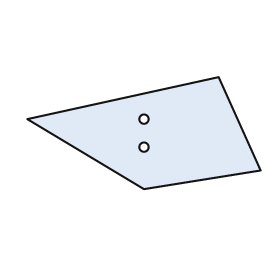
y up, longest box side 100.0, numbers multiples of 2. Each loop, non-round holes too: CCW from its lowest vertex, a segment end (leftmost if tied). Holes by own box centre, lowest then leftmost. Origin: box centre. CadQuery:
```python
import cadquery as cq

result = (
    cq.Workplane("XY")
    .moveTo(0.0, -24.0)
    .lineTo(50.0, -16.0)
    .lineTo(32.0, 24.0)
    .lineTo(-50.0, 6.0)
    .close()
    .moveTo(0.0, -6.0)
    .circle(2.0)
    .moveTo(0.0, 6.0)
    .circle(2.0)
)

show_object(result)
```